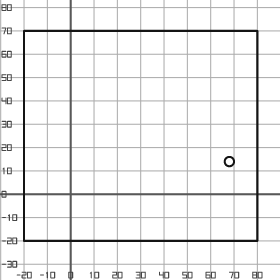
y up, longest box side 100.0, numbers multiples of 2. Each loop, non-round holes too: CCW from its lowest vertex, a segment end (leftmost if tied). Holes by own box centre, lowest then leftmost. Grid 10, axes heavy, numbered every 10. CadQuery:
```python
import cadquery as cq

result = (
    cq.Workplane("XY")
    .moveTo(-20.0, -20.0)
    .lineTo(80.0, -20.0)
    .lineTo(80.0, 70.0)
    .lineTo(-20.0, 70.0)
    .close()
    .moveTo(68.0, 14.0)
    .circle(2.0)
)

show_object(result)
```